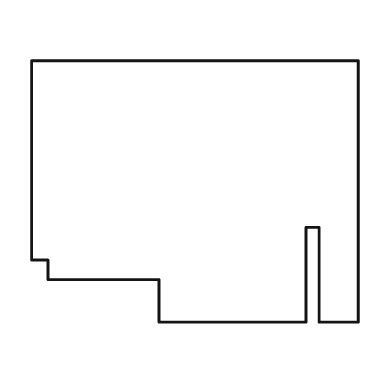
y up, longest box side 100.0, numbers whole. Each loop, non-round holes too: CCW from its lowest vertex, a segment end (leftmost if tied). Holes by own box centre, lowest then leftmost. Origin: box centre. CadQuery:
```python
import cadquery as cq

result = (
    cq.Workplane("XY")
    .moveTo(-11.0, -40.0)
    .lineTo(34.0, -40.0)
    .lineTo(34.0, -11.0)
    .lineTo(38.0, -11.0)
    .lineTo(38.0, -40.0)
    .lineTo(50.0, -40.0)
    .lineTo(50.0, 40.0)
    .lineTo(-50.0, 40.0)
    .lineTo(-50.0, -21.0)
    .lineTo(-45.0, -21.0)
    .lineTo(-45.0, -27.0)
    .lineTo(-11.0, -27.0)
    .close()
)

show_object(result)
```